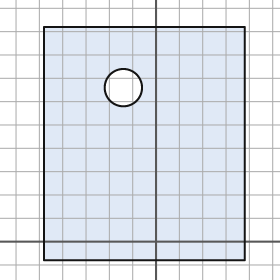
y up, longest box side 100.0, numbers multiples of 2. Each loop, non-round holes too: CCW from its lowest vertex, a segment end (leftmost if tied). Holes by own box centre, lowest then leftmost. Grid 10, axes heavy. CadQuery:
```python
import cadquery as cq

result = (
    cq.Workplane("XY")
    .moveTo(-48.0, -8.0)
    .lineTo(38.0, -8.0)
    .lineTo(38.0, 92.0)
    .lineTo(-48.0, 92.0)
    .close()
    .moveTo(-14.0, 66.0)
    .circle(8.0)
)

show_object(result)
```